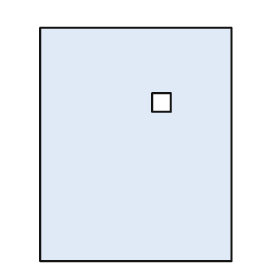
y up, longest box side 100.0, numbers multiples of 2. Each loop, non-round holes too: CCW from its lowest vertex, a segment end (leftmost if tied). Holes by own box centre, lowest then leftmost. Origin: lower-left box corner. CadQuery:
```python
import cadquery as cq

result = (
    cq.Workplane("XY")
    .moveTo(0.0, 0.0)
    .lineTo(82.0, 0.0)
    .lineTo(82.0, 100.0)
    .lineTo(0.0, 100.0)
    .close()
    .moveTo(48.0, 64.0)
    .lineTo(56.0, 64.0)
    .lineTo(56.0, 72.0)
    .lineTo(48.0, 72.0)
    .close()
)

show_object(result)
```